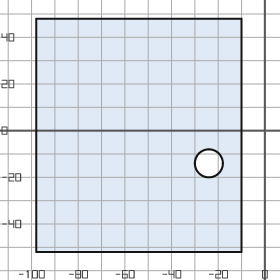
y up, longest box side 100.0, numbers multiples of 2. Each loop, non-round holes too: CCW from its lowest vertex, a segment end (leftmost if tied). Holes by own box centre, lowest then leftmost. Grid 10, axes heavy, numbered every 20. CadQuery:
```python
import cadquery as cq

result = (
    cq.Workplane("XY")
    .moveTo(-98.0, -52.0)
    .lineTo(-10.0, -52.0)
    .lineTo(-10.0, 48.0)
    .lineTo(-98.0, 48.0)
    .close()
    .moveTo(-24.0, -14.0)
    .circle(6.0)
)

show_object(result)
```